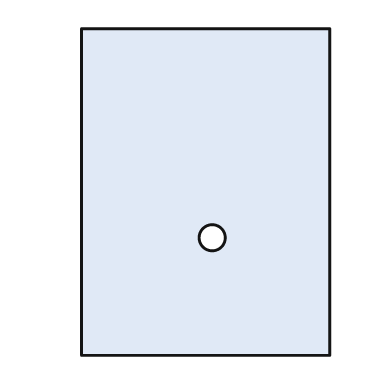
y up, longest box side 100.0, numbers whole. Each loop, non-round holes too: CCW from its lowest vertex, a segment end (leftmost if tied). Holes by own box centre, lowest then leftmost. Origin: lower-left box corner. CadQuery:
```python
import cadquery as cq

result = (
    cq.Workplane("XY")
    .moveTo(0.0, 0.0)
    .lineTo(76.0, 0.0)
    .lineTo(76.0, 100.0)
    .lineTo(0.0, 100.0)
    .close()
    .moveTo(40.0, 36.0)
    .circle(4.0)
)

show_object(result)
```